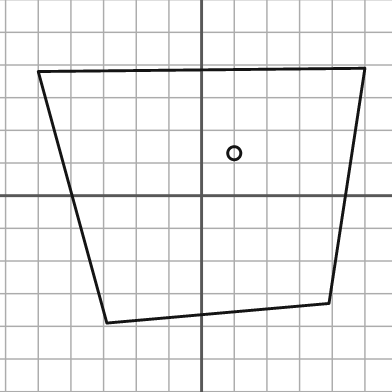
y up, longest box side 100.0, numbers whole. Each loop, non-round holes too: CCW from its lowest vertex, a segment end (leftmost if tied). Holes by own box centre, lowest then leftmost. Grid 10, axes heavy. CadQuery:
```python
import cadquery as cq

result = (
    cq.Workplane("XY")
    .moveTo(-29.0, -39.0)
    .lineTo(39.0, -33.0)
    .lineTo(50.0, 39.0)
    .lineTo(-50.0, 38.0)
    .close()
    .moveTo(10.0, 13.0)
    .circle(2.0)
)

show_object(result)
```